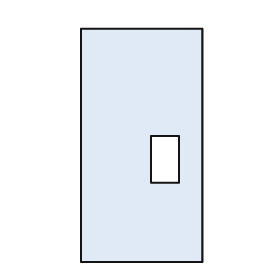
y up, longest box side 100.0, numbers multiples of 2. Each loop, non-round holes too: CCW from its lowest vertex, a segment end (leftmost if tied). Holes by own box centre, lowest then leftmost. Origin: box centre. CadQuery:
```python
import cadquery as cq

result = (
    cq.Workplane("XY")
    .moveTo(-26.0, -50.0)
    .lineTo(26.0, -50.0)
    .lineTo(26.0, 50.0)
    .lineTo(-26.0, 50.0)
    .close()
    .moveTo(4.0, -16.0)
    .lineTo(16.0, -16.0)
    .lineTo(16.0, 4.0)
    .lineTo(4.0, 4.0)
    .close()
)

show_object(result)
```